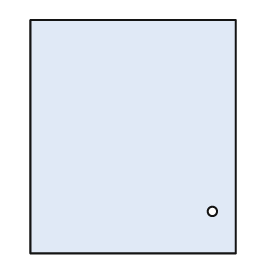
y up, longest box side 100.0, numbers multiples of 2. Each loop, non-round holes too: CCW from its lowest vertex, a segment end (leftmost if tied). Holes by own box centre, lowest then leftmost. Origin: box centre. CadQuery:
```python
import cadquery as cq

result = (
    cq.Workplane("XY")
    .moveTo(-44.0, -50.0)
    .lineTo(44.0, -50.0)
    .lineTo(44.0, 50.0)
    .lineTo(-44.0, 50.0)
    .close()
    .moveTo(34.0, -32.0)
    .circle(2.0)
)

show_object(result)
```